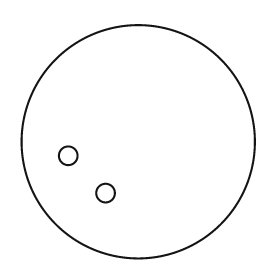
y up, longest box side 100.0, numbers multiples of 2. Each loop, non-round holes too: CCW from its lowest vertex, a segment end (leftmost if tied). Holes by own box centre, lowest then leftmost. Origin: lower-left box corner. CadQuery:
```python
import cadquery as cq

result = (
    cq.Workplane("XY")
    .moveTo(50.0, 50.0)
    .circle(50.0)
    .moveTo(36.0, 28.0)
    .circle(4.0)
    .moveTo(20.0, 44.0)
    .circle(4.0)
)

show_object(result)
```